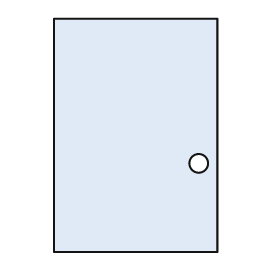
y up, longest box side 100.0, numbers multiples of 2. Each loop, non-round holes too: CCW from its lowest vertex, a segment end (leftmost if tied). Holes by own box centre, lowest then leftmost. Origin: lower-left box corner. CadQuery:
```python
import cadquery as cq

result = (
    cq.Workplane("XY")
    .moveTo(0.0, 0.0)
    .lineTo(70.0, 0.0)
    .lineTo(70.0, 100.0)
    .lineTo(0.0, 100.0)
    .close()
    .moveTo(62.0, 38.0)
    .circle(4.0)
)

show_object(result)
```